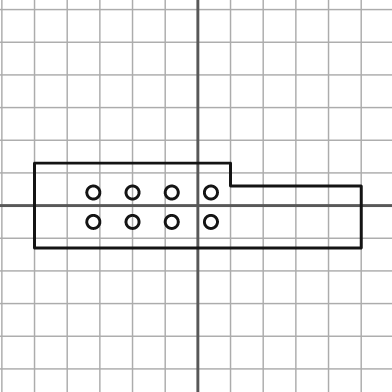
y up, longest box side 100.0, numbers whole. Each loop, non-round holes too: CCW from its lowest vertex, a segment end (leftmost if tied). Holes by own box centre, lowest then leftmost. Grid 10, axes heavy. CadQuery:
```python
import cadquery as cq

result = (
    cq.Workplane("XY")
    .moveTo(-50.0, -13.0)
    .lineTo(50.0, -13.0)
    .lineTo(50.0, 6.0)
    .lineTo(10.0, 6.0)
    .lineTo(10.0, 13.0)
    .lineTo(-50.0, 13.0)
    .close()
    .moveTo(-32.0, -5.0)
    .circle(2.0)
    .moveTo(-20.0, -5.0)
    .circle(2.0)
    .moveTo(-8.0, -5.0)
    .circle(2.0)
    .moveTo(4.0, -5.0)
    .circle(2.0)
    .moveTo(-32.0, 4.0)
    .circle(2.0)
    .moveTo(-20.0, 4.0)
    .circle(2.0)
    .moveTo(-8.0, 4.0)
    .circle(2.0)
    .moveTo(4.0, 4.0)
    .circle(2.0)
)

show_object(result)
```